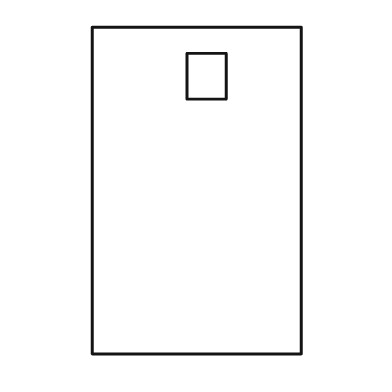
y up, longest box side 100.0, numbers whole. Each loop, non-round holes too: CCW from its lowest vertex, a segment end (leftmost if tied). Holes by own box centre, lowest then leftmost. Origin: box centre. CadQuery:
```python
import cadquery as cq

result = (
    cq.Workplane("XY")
    .moveTo(-32.0, -50.0)
    .lineTo(32.0, -50.0)
    .lineTo(32.0, 50.0)
    .lineTo(-32.0, 50.0)
    .close()
    .moveTo(-3.0, 28.0)
    .lineTo(9.0, 28.0)
    .lineTo(9.0, 42.0)
    .lineTo(-3.0, 42.0)
    .close()
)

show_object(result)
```